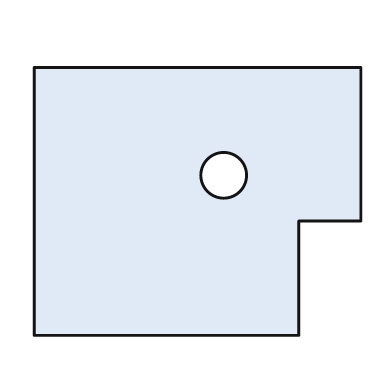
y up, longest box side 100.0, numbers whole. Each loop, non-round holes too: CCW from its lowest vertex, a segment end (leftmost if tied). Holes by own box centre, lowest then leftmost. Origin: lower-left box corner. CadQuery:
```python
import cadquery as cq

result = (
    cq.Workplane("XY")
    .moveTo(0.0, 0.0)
    .lineTo(81.0, 0.0)
    .lineTo(81.0, 35.0)
    .lineTo(100.0, 35.0)
    .lineTo(100.0, 82.0)
    .lineTo(0.0, 82.0)
    .close()
    .moveTo(58.0, 49.0)
    .circle(7.0)
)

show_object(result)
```